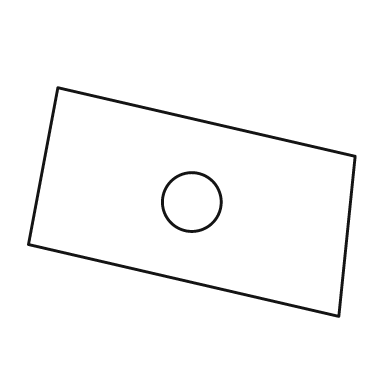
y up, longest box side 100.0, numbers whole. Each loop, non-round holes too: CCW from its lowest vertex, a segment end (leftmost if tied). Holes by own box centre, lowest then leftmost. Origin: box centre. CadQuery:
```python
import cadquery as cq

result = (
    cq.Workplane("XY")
    .moveTo(45.0, -35.0)
    .lineTo(50.0, 14.0)
    .lineTo(-41.0, 35.0)
    .lineTo(-50.0, -13.0)
    .close()
    .moveTo(0.0, 0.0)
    .circle(9.0)
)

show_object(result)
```